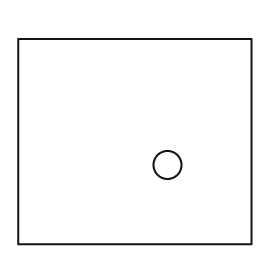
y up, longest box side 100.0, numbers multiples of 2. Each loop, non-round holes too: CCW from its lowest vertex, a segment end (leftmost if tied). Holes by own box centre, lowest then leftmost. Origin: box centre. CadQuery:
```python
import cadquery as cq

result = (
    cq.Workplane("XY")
    .moveTo(-50.0, -44.0)
    .lineTo(50.0, -44.0)
    .lineTo(50.0, 44.0)
    .lineTo(-50.0, 44.0)
    .close()
    .moveTo(14.0, -10.0)
    .circle(6.0)
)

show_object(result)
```